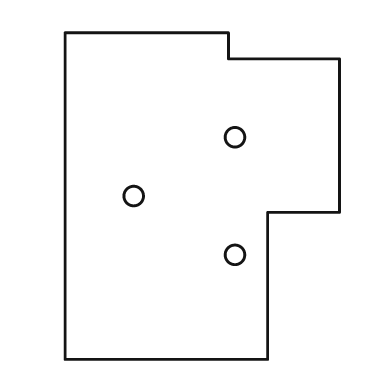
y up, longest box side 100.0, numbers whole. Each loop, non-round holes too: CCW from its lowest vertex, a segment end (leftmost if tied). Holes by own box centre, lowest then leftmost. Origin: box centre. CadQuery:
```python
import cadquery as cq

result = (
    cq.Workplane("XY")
    .moveTo(-42.0, -50.0)
    .lineTo(20.0, -50.0)
    .lineTo(20.0, -5.0)
    .lineTo(42.0, -5.0)
    .lineTo(42.0, 42.0)
    .lineTo(8.0, 42.0)
    .lineTo(8.0, 50.0)
    .lineTo(-42.0, 50.0)
    .close()
    .moveTo(10.0, -18.0)
    .circle(3.0)
    .moveTo(-21.0, 0.0)
    .circle(3.0)
    .moveTo(10.0, 18.0)
    .circle(3.0)
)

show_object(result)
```